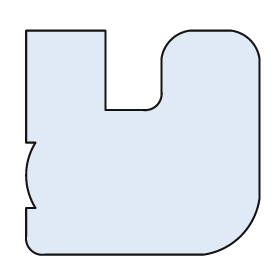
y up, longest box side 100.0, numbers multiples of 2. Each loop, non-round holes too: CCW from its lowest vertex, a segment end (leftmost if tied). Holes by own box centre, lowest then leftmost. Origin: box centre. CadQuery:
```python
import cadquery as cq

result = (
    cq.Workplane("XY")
    .moveTo(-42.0, -48.0)
    .lineTo(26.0, -48.0)
    .threePointArc((42.0, -40.0), (50.0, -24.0))
    .lineTo(50.0, 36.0)
    .threePointArc((46.0, 44.0), (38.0, 48.0))
    .lineTo(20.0, 48.0)
    .threePointArc((12.0, 44.0), (8.0, 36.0))
    .lineTo(8.0, 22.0)
    .threePointArc((6.0, 16.0), (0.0, 14.0))
    .lineTo(-16.0, 14.0)
    .lineTo(-16.0, 48.0)
    .lineTo(-50.0, 48.0)
    .lineTo(-50.0, 0.0)
    .lineTo(-46.0, 0.0)
    .threePointArc((-50.0, -14.0), (-46.0, -28.0))
    .lineTo(-50.0, -28.0)
    .lineTo(-50.0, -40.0)
    .threePointArc((-48.0, -46.0), (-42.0, -48.0))
    .close()
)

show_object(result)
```